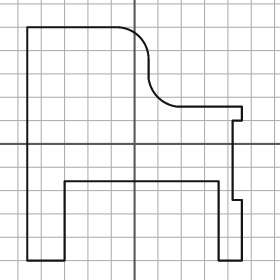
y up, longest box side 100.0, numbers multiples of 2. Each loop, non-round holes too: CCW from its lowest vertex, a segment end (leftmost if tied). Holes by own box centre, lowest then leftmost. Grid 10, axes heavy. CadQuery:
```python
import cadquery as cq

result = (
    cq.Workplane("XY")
    .moveTo(-46.0, -50.0)
    .lineTo(-30.0, -50.0)
    .lineTo(-30.0, -16.0)
    .lineTo(36.0, -16.0)
    .lineTo(36.0, -50.0)
    .lineTo(46.0, -50.0)
    .lineTo(46.0, -24.0)
    .lineTo(42.0, -24.0)
    .lineTo(42.0, 10.0)
    .lineTo(46.0, 10.0)
    .lineTo(46.0, 16.0)
    .lineTo(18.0, 16.0)
    .threePointArc((10.0, 20.0), (6.0, 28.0))
    .lineTo(6.0, 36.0)
    .threePointArc((2.0, 46.0), (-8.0, 50.0))
    .lineTo(-46.0, 50.0)
    .close()
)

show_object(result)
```